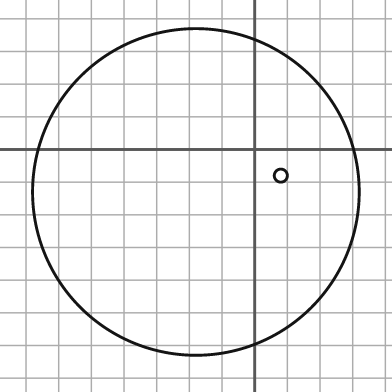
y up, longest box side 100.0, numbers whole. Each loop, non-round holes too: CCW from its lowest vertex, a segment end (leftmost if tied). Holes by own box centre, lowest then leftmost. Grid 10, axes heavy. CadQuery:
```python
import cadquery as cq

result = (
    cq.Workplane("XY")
    .moveTo(-18.0, -13.0)
    .circle(50.0)
    .moveTo(8.0, -8.0)
    .circle(2.0)
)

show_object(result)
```